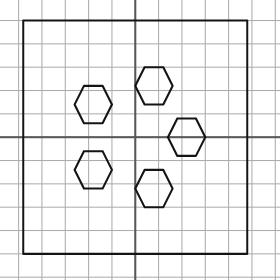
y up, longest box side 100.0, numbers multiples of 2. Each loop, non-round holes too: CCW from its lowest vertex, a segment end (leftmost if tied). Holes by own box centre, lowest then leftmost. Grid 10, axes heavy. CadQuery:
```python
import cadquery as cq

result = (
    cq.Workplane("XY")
    .moveTo(-48.0, -50.0)
    .lineTo(48.0, -50.0)
    .lineTo(48.0, 50.0)
    .lineTo(-48.0, 50.0)
    .close()
    .moveTo(4.0, -30.0)
    .lineTo(12.0, -30.0)
    .lineTo(16.0, -22.0)
    .lineTo(12.0, -14.0)
    .lineTo(4.0, -14.0)
    .lineTo(0.0, -22.0)
    .close()
    .moveTo(-22.0, -22.0)
    .lineTo(-14.0, -22.0)
    .lineTo(-10.0, -14.0)
    .lineTo(-14.0, -6.0)
    .lineTo(-22.0, -6.0)
    .lineTo(-26.0, -14.0)
    .close()
    .moveTo(18.0, -8.0)
    .lineTo(26.0, -8.0)
    .lineTo(30.0, 0.0)
    .lineTo(26.0, 8.0)
    .lineTo(18.0, 8.0)
    .lineTo(14.0, 0.0)
    .close()
    .moveTo(-22.0, 6.0)
    .lineTo(-14.0, 6.0)
    .lineTo(-10.0, 14.0)
    .lineTo(-14.0, 22.0)
    .lineTo(-22.0, 22.0)
    .lineTo(-26.0, 14.0)
    .close()
    .moveTo(4.0, 14.0)
    .lineTo(12.0, 14.0)
    .lineTo(16.0, 22.0)
    .lineTo(12.0, 30.0)
    .lineTo(4.0, 30.0)
    .lineTo(0.0, 22.0)
    .close()
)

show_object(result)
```